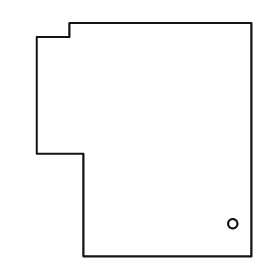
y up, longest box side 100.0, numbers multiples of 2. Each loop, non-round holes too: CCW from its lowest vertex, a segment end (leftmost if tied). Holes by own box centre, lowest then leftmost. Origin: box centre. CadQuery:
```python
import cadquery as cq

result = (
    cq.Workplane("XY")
    .moveTo(-26.0, -50.0)
    .lineTo(46.0, -50.0)
    .lineTo(46.0, 50.0)
    .lineTo(-32.0, 50.0)
    .lineTo(-32.0, 44.0)
    .lineTo(-46.0, 44.0)
    .lineTo(-46.0, -6.0)
    .lineTo(-26.0, -6.0)
    .close()
    .moveTo(38.0, -36.0)
    .circle(2.0)
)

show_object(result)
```